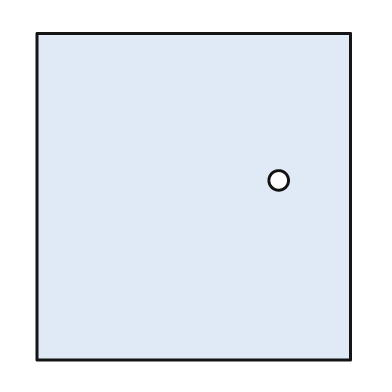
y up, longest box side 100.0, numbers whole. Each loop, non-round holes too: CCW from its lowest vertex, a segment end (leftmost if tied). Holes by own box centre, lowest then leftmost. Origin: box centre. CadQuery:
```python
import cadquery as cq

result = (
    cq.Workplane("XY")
    .moveTo(-48.0, -50.0)
    .lineTo(48.0, -50.0)
    .lineTo(48.0, 50.0)
    .lineTo(-48.0, 50.0)
    .close()
    .moveTo(26.0, 5.0)
    .circle(3.0)
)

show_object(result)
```